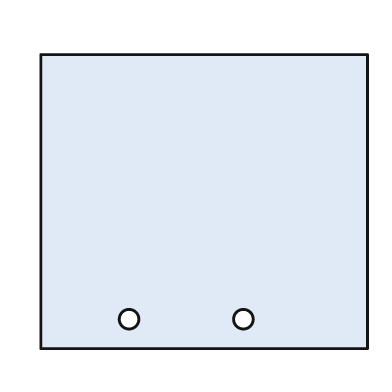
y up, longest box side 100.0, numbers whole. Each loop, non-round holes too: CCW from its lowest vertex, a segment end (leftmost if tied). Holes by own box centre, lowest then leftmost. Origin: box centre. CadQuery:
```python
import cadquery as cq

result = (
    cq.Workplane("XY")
    .moveTo(-50.0, -45.0)
    .lineTo(50.0, -45.0)
    .lineTo(50.0, 45.0)
    .lineTo(-50.0, 45.0)
    .close()
    .moveTo(-23.0, -36.0)
    .circle(3.0)
    .moveTo(12.0, -36.0)
    .circle(3.0)
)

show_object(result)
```